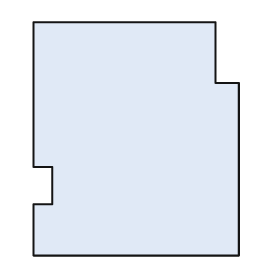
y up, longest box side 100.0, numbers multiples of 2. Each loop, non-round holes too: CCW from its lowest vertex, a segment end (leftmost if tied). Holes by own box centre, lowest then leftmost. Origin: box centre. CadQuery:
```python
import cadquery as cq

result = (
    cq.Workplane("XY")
    .moveTo(-44.0, -50.0)
    .lineTo(44.0, -50.0)
    .lineTo(44.0, 24.0)
    .lineTo(34.0, 24.0)
    .lineTo(34.0, 50.0)
    .lineTo(-44.0, 50.0)
    .lineTo(-44.0, -12.0)
    .lineTo(-36.0, -12.0)
    .lineTo(-36.0, -28.0)
    .lineTo(-44.0, -28.0)
    .close()
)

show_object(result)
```